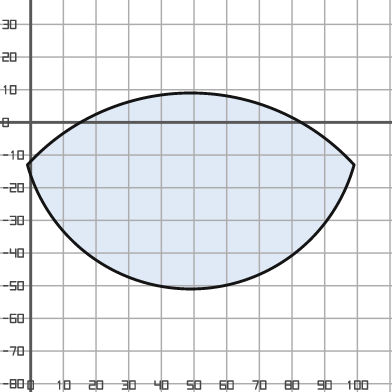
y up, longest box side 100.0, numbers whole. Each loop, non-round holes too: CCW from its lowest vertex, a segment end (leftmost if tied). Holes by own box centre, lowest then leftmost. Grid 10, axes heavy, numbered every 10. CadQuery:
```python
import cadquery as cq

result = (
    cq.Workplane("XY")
    .moveTo(-1.0, -13.0)
    .threePointArc((49.0, -51.0), (99.0, -13.0))
    .threePointArc((49.0, 9.0), (-1.0, -13.0))
    .close()
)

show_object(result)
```